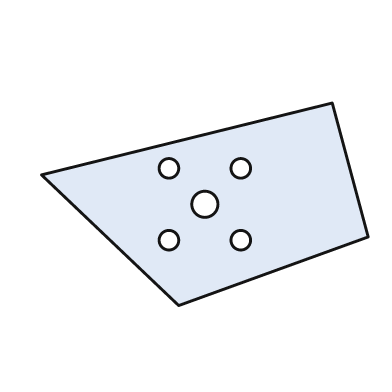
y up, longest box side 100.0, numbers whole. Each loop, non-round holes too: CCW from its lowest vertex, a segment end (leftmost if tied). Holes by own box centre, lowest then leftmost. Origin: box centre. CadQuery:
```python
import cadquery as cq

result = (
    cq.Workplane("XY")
    .moveTo(-8.0, -31.0)
    .lineTo(50.0, -10.0)
    .lineTo(39.0, 31.0)
    .lineTo(-50.0, 9.0)
    .close()
    .moveTo(-11.0, -11.0)
    .circle(3.0)
    .moveTo(11.0, -11.0)
    .circle(3.0)
    .moveTo(0.0, 0.0)
    .circle(4.0)
    .moveTo(-11.0, 11.0)
    .circle(3.0)
    .moveTo(11.0, 11.0)
    .circle(3.0)
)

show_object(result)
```